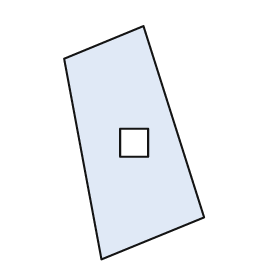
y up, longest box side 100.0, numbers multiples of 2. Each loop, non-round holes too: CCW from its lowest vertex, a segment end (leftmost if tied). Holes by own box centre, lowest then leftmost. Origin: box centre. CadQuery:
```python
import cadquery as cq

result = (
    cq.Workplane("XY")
    .moveTo(-14.0, -50.0)
    .lineTo(30.0, -32.0)
    .lineTo(4.0, 50.0)
    .lineTo(-30.0, 36.0)
    .close()
    .moveTo(-6.0, -6.0)
    .lineTo(6.0, -6.0)
    .lineTo(6.0, 6.0)
    .lineTo(-6.0, 6.0)
    .close()
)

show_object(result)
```